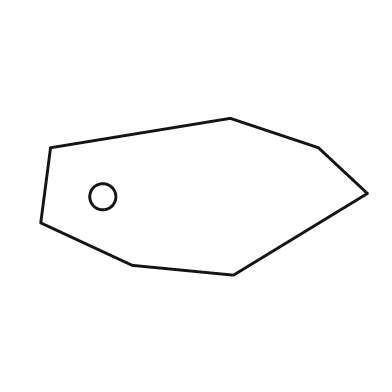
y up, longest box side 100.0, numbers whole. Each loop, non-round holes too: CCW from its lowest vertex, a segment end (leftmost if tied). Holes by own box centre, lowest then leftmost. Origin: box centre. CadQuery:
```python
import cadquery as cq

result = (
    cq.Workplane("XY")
    .moveTo(9.0, -24.0)
    .lineTo(50.0, 1.0)
    .lineTo(35.0, 15.0)
    .lineTo(8.0, 24.0)
    .lineTo(-47.0, 15.0)
    .lineTo(-50.0, -8.0)
    .lineTo(-22.0, -21.0)
    .close()
    .moveTo(-31.0, 0.0)
    .circle(4.0)
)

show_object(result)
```